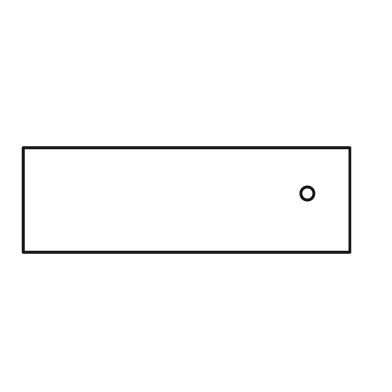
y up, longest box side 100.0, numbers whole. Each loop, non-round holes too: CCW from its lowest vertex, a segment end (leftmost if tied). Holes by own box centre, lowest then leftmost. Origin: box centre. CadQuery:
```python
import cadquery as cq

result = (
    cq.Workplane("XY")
    .moveTo(-50.0, -16.0)
    .lineTo(50.0, -16.0)
    .lineTo(50.0, 16.0)
    .lineTo(-50.0, 16.0)
    .close()
    .moveTo(37.0, 2.0)
    .circle(2.0)
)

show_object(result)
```